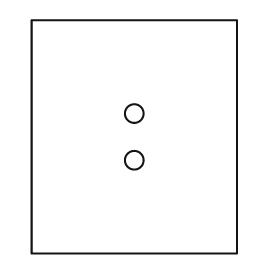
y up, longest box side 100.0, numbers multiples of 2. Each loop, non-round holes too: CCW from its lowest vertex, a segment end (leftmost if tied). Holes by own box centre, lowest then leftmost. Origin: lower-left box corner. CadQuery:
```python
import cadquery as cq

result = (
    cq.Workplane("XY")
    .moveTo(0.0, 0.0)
    .lineTo(88.0, 0.0)
    .lineTo(88.0, 100.0)
    .lineTo(0.0, 100.0)
    .close()
    .moveTo(44.0, 40.0)
    .circle(4.0)
    .moveTo(44.0, 60.0)
    .circle(4.0)
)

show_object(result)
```